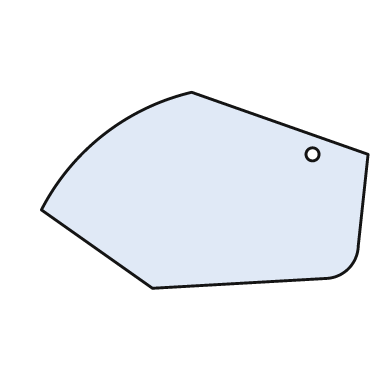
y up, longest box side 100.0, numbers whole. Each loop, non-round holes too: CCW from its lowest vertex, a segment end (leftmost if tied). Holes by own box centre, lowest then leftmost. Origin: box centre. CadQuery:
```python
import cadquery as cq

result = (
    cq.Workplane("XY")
    .moveTo(-16.0, -30.0)
    .lineTo(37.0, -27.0)
    .threePointArc((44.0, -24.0), (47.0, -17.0))
    .lineTo(50.0, 11.0)
    .lineTo(-4.0, 30.0)
    .threePointArc((-31.0, 17.0), (-50.0, -6.0))
    .close()
    .moveTo(33.0, 11.0)
    .circle(2.0)
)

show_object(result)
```